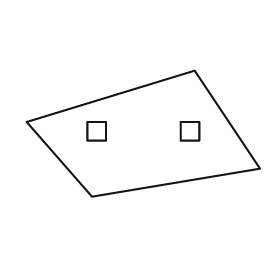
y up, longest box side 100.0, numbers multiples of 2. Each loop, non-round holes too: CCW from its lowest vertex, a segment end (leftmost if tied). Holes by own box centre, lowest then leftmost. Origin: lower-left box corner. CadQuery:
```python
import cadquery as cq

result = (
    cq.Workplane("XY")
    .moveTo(28.0, 0.0)
    .lineTo(100.0, 12.0)
    .lineTo(72.0, 54.0)
    .lineTo(0.0, 32.0)
    .close()
    .moveTo(26.0, 24.0)
    .lineTo(34.0, 24.0)
    .lineTo(34.0, 32.0)
    .lineTo(26.0, 32.0)
    .close()
    .moveTo(66.0, 24.0)
    .lineTo(74.0, 24.0)
    .lineTo(74.0, 32.0)
    .lineTo(66.0, 32.0)
    .close()
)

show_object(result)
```